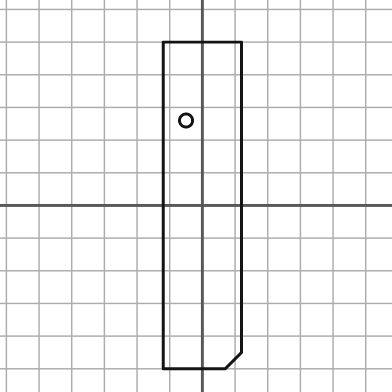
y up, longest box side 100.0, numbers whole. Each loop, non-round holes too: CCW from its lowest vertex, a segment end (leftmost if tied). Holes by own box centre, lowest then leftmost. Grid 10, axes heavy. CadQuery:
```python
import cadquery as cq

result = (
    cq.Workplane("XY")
    .moveTo(-12.0, -50.0)
    .lineTo(7.0, -50.0)
    .lineTo(12.0, -45.0)
    .lineTo(12.0, 50.0)
    .lineTo(-12.0, 50.0)
    .close()
    .moveTo(-5.0, 26.0)
    .circle(2.0)
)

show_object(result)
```